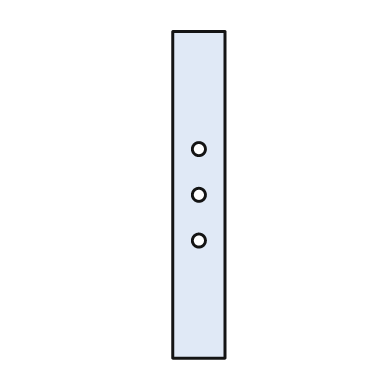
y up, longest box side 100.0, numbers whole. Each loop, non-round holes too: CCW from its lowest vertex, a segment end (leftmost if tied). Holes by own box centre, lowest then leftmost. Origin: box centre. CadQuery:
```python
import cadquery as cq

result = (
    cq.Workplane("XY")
    .moveTo(-8.0, -50.0)
    .lineTo(8.0, -50.0)
    .lineTo(8.0, 50.0)
    .lineTo(-8.0, 50.0)
    .close()
    .moveTo(0.0, -14.0)
    .circle(2.0)
    .moveTo(0.0, 0.0)
    .circle(2.0)
    .moveTo(0.0, 14.0)
    .circle(2.0)
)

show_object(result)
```